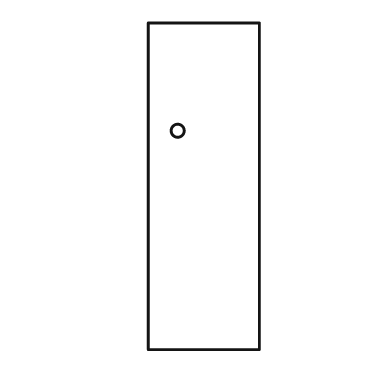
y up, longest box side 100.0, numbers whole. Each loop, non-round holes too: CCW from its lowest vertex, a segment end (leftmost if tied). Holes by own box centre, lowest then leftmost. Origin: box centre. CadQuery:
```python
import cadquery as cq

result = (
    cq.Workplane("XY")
    .moveTo(-17.0, -50.0)
    .lineTo(17.0, -50.0)
    .lineTo(17.0, 50.0)
    .lineTo(-17.0, 50.0)
    .close()
    .moveTo(-8.0, 17.0)
    .circle(2.0)
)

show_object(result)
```